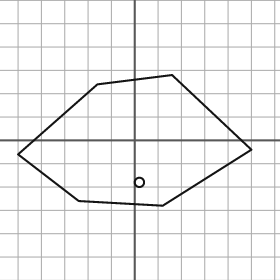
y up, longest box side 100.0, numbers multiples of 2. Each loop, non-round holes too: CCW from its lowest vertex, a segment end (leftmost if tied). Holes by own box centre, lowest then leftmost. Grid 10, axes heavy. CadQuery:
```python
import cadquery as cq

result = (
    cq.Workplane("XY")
    .moveTo(12.0, -28.0)
    .lineTo(50.0, -4.0)
    .lineTo(16.0, 28.0)
    .lineTo(-16.0, 24.0)
    .lineTo(-50.0, -6.0)
    .lineTo(-24.0, -26.0)
    .close()
    .moveTo(2.0, -18.0)
    .circle(2.0)
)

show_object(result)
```